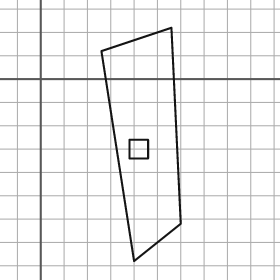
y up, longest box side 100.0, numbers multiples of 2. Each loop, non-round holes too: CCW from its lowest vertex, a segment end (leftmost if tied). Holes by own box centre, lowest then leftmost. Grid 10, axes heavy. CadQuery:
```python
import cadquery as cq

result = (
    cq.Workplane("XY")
    .moveTo(40.0, -78.0)
    .lineTo(60.0, -62.0)
    .lineTo(56.0, 22.0)
    .lineTo(26.0, 12.0)
    .close()
    .moveTo(38.0, -34.0)
    .lineTo(46.0, -34.0)
    .lineTo(46.0, -26.0)
    .lineTo(38.0, -26.0)
    .close()
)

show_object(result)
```